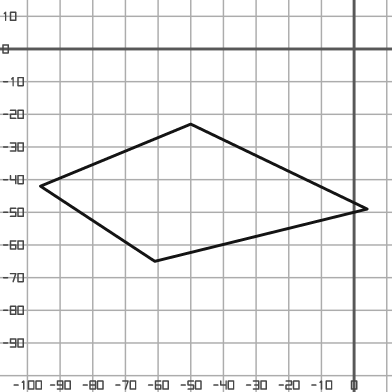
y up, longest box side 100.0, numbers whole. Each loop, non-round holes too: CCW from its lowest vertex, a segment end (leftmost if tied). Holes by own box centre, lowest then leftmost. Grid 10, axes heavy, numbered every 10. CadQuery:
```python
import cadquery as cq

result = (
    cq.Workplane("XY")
    .moveTo(-61.0, -65.0)
    .lineTo(4.0, -49.0)
    .lineTo(-50.0, -23.0)
    .lineTo(-96.0, -42.0)
    .close()
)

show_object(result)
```